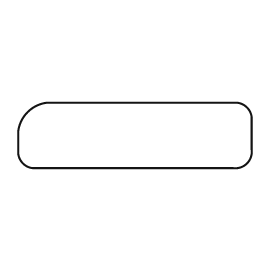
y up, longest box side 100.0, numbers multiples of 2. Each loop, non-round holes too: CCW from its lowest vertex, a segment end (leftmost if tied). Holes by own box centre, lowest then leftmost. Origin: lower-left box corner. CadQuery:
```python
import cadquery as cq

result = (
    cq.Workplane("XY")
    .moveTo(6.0, 0.0)
    .lineTo(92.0, 0.0)
    .threePointArc((98.0, 2.0), (100.0, 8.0))
    .lineTo(100.0, 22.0)
    .threePointArc((98.0, 26.0), (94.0, 28.0))
    .lineTo(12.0, 28.0)
    .threePointArc((4.0, 24.0), (0.0, 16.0))
    .lineTo(0.0, 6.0)
    .threePointArc((2.0, 2.0), (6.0, 0.0))
    .close()
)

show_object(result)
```